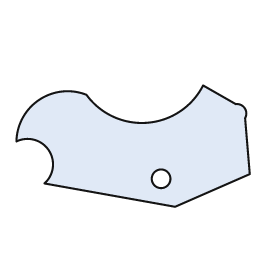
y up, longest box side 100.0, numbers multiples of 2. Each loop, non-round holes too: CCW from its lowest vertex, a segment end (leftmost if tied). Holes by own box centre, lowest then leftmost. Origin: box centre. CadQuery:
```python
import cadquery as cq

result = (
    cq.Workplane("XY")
    .moveTo(18.0, -26.0)
    .lineTo(50.0, -12.0)
    .lineTo(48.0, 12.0)
    .threePointArc((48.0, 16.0), (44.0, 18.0))
    .lineTo(30.0, 26.0)
    .threePointArc((6.0, 10.0), (-20.0, 22.0))
    .threePointArc((-40.0, 20.0), (-50.0, 2.0))
    .threePointArc((-36.0, -2.0), (-38.0, -16.0))
    .close()
    .moveTo(12.0, -14.0)
    .circle(4.0)
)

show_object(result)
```